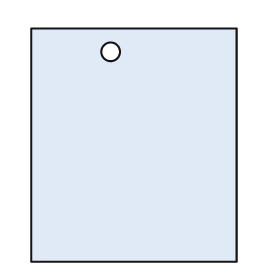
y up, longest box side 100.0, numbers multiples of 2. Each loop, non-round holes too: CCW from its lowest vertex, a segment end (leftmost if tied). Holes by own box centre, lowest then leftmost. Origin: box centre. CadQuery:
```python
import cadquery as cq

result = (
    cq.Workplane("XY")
    .moveTo(-44.0, -50.0)
    .lineTo(44.0, -50.0)
    .lineTo(44.0, 50.0)
    .lineTo(-44.0, 50.0)
    .close()
    .moveTo(-10.0, 40.0)
    .circle(4.0)
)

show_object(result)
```